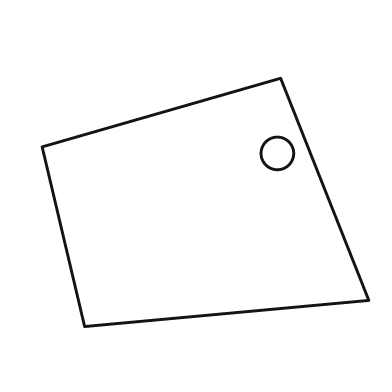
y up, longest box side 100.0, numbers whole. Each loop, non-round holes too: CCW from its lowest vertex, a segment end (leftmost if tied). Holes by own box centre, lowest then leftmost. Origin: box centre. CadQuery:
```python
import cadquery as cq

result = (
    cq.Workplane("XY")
    .moveTo(-37.0, -38.0)
    .lineTo(50.0, -30.0)
    .lineTo(23.0, 38.0)
    .lineTo(-50.0, 17.0)
    .close()
    .moveTo(22.0, 15.0)
    .circle(5.0)
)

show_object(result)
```